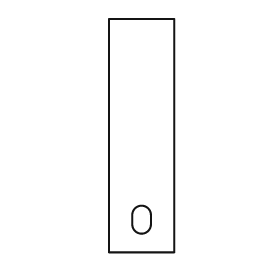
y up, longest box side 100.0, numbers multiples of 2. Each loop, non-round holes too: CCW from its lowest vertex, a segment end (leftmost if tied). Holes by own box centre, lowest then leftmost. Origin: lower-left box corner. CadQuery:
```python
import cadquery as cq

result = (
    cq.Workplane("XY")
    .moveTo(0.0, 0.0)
    .lineTo(28.0, 0.0)
    .lineTo(28.0, 100.0)
    .lineTo(0.0, 100.0)
    .close()
    .moveTo(10.0, 12.0)
    .threePointArc((14.0, 8.0), (18.0, 12.0))
    .lineTo(18.0, 16.0)
    .threePointArc((14.0, 20.0), (10.0, 16.0))
    .close()
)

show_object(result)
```